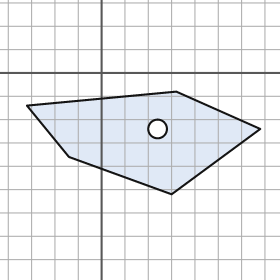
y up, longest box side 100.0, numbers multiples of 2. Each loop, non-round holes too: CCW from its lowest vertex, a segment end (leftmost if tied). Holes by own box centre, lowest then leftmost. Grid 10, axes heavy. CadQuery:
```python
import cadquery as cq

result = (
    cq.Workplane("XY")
    .moveTo(30.0, -52.0)
    .lineTo(68.0, -24.0)
    .lineTo(32.0, -8.0)
    .lineTo(-32.0, -14.0)
    .lineTo(-14.0, -36.0)
    .close()
    .moveTo(24.0, -24.0)
    .circle(4.0)
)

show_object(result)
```